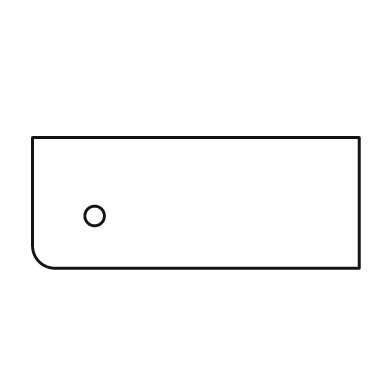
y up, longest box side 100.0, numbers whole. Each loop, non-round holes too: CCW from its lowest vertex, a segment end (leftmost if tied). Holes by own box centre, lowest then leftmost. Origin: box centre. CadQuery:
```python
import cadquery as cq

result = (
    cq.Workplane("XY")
    .moveTo(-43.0, -20.0)
    .lineTo(50.0, -20.0)
    .lineTo(50.0, 20.0)
    .lineTo(-50.0, 20.0)
    .lineTo(-50.0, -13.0)
    .threePointArc((-48.0, -18.0), (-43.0, -20.0))
    .close()
    .moveTo(-31.0, -4.0)
    .circle(3.0)
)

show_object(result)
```